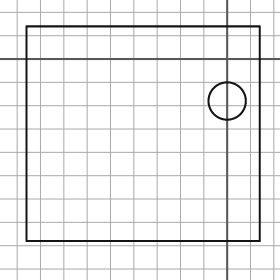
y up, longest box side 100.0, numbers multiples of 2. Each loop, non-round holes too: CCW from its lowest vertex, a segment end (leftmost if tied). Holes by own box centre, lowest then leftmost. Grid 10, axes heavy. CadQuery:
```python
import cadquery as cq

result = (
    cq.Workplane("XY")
    .moveTo(-86.0, -78.0)
    .lineTo(14.0, -78.0)
    .lineTo(14.0, 14.0)
    .lineTo(-86.0, 14.0)
    .close()
    .moveTo(0.0, -18.0)
    .circle(8.0)
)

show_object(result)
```